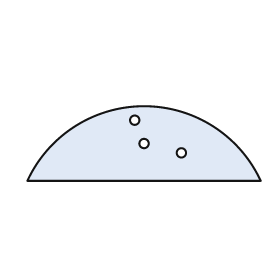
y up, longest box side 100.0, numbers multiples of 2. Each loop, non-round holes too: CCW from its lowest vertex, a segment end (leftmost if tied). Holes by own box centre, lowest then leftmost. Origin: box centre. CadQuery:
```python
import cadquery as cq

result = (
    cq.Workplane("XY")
    .moveTo(-50.0, -16.0)
    .lineTo(50.0, -16.0)
    .threePointArc((0.0, 16.0), (-50.0, -16.0))
    .close()
    .moveTo(16.0, -4.0)
    .circle(2.0)
    .moveTo(0.0, 0.0)
    .circle(2.0)
    .moveTo(-4.0, 10.0)
    .circle(2.0)
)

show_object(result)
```